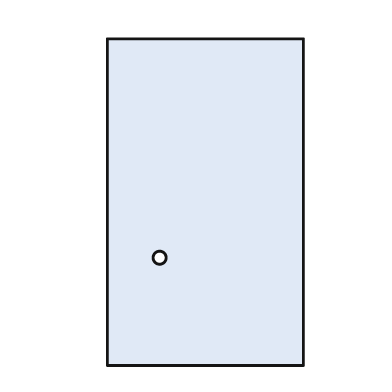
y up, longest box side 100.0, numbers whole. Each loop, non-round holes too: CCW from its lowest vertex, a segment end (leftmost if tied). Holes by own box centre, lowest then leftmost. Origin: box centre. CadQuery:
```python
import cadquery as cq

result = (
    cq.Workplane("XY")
    .moveTo(-30.0, -50.0)
    .lineTo(30.0, -50.0)
    .lineTo(30.0, 50.0)
    .lineTo(-30.0, 50.0)
    .close()
    .moveTo(-14.0, -17.0)
    .circle(2.0)
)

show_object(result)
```